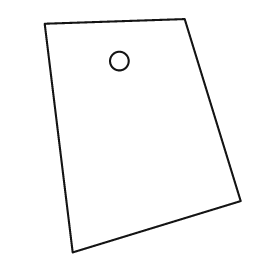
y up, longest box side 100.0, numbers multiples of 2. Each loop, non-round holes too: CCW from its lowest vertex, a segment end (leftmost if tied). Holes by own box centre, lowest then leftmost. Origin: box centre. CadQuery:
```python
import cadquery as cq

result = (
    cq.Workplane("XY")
    .moveTo(-30.0, -50.0)
    .lineTo(42.0, -28.0)
    .lineTo(18.0, 50.0)
    .lineTo(-42.0, 48.0)
    .close()
    .moveTo(-10.0, 32.0)
    .circle(4.0)
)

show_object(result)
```